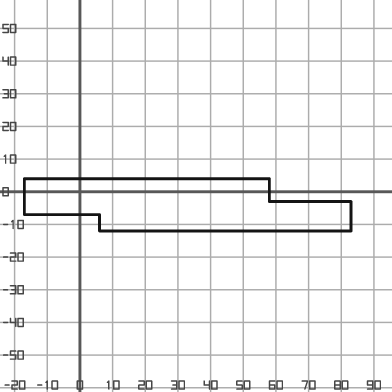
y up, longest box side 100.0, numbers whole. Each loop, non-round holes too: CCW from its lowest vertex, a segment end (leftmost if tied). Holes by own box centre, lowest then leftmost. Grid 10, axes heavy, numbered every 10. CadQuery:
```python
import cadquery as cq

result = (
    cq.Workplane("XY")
    .moveTo(6.0, -12.0)
    .lineTo(83.0, -12.0)
    .lineTo(83.0, -3.0)
    .lineTo(58.0, -3.0)
    .lineTo(58.0, 4.0)
    .lineTo(-17.0, 4.0)
    .lineTo(-17.0, -7.0)
    .lineTo(6.0, -7.0)
    .close()
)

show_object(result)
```